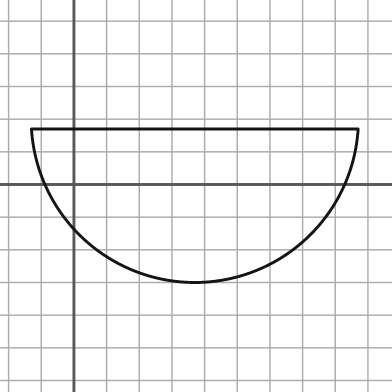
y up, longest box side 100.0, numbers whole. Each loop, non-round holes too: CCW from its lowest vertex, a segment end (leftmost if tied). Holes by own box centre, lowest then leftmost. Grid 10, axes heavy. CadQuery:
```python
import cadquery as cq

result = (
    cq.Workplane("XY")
    .moveTo(-13.0, 17.0)
    .threePointArc((37.0, -30.0), (87.0, 17.0))
    .close()
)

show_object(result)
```